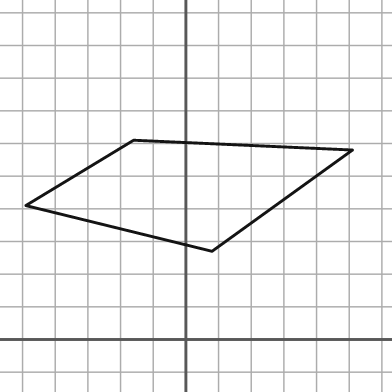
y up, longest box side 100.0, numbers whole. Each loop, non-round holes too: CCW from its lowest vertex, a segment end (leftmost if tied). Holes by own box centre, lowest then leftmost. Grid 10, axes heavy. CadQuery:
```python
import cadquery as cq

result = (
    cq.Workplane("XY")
    .moveTo(8.0, 27.0)
    .lineTo(51.0, 58.0)
    .lineTo(-16.0, 61.0)
    .lineTo(-49.0, 41.0)
    .close()
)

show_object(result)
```